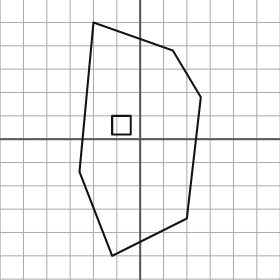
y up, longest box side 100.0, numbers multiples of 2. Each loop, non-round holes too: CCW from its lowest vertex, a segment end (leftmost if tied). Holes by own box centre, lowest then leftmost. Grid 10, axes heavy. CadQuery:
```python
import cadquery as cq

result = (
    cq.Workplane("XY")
    .moveTo(-12.0, -50.0)
    .lineTo(20.0, -34.0)
    .lineTo(26.0, 18.0)
    .lineTo(14.0, 38.0)
    .lineTo(-20.0, 50.0)
    .lineTo(-26.0, -14.0)
    .close()
    .moveTo(-12.0, 2.0)
    .lineTo(-4.0, 2.0)
    .lineTo(-4.0, 10.0)
    .lineTo(-12.0, 10.0)
    .close()
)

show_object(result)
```